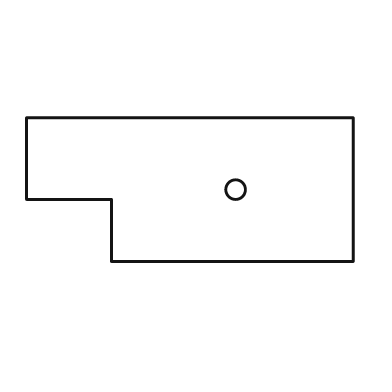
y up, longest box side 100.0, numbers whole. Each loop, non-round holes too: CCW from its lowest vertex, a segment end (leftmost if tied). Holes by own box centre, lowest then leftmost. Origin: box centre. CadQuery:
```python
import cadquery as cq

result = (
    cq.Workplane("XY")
    .moveTo(-24.0, -22.0)
    .lineTo(50.0, -22.0)
    .lineTo(50.0, 22.0)
    .lineTo(-50.0, 22.0)
    .lineTo(-50.0, -3.0)
    .lineTo(-24.0, -3.0)
    .close()
    .moveTo(14.0, 0.0)
    .circle(3.0)
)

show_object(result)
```